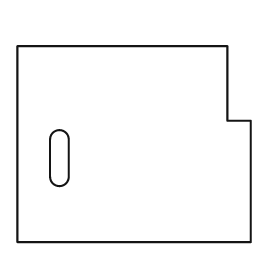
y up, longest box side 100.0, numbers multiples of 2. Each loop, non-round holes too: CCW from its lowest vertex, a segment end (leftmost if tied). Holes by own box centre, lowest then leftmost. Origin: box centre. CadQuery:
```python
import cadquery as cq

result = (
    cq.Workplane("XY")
    .moveTo(-50.0, -42.0)
    .lineTo(50.0, -42.0)
    .lineTo(50.0, 10.0)
    .lineTo(40.0, 10.0)
    .lineTo(40.0, 42.0)
    .lineTo(-50.0, 42.0)
    .close()
    .moveTo(-36.0, -14.0)
    .threePointArc((-32.0, -18.0), (-28.0, -14.0))
    .lineTo(-28.0, 2.0)
    .threePointArc((-32.0, 6.0), (-36.0, 2.0))
    .close()
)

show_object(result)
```